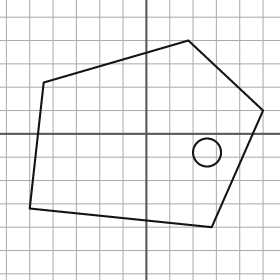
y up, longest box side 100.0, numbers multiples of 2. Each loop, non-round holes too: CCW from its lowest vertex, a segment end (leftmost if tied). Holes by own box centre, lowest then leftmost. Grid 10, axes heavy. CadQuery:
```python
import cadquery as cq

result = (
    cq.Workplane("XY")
    .moveTo(28.0, -40.0)
    .lineTo(50.0, 10.0)
    .lineTo(18.0, 40.0)
    .lineTo(-44.0, 22.0)
    .lineTo(-50.0, -32.0)
    .close()
    .moveTo(26.0, -8.0)
    .circle(6.0)
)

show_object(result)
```